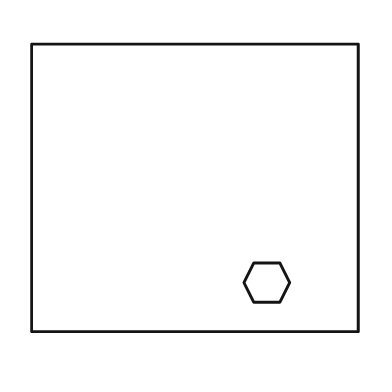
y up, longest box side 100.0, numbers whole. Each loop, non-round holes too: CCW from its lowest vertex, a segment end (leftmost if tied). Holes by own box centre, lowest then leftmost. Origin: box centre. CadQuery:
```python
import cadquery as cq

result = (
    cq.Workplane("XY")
    .moveTo(-50.0, -44.0)
    .lineTo(50.0, -44.0)
    .lineTo(50.0, 44.0)
    .lineTo(-50.0, 44.0)
    .close()
    .moveTo(18.0, -35.0)
    .lineTo(26.0, -35.0)
    .lineTo(29.0, -29.0)
    .lineTo(26.0, -23.0)
    .lineTo(18.0, -23.0)
    .lineTo(15.0, -29.0)
    .close()
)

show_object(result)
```